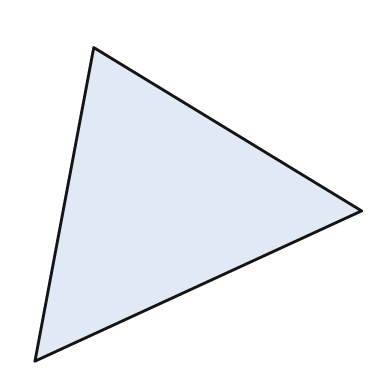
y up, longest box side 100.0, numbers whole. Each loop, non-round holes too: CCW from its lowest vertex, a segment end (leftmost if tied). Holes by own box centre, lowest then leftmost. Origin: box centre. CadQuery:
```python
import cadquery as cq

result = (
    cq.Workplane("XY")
    .moveTo(-50.0, -48.0)
    .lineTo(50.0, -2.0)
    .lineTo(-32.0, 48.0)
    .close()
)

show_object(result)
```